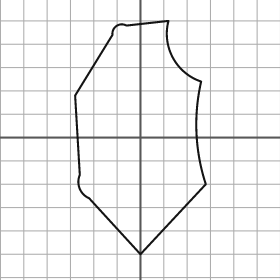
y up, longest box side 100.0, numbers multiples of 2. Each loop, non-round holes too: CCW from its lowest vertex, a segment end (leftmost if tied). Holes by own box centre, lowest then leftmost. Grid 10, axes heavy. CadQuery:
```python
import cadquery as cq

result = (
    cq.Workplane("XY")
    .moveTo(0.0, -50.0)
    .lineTo(28.0, -20.0)
    .threePointArc((24.0, 2.0), (26.0, 24.0))
    .threePointArc((14.0, 34.0), (12.0, 50.0))
    .lineTo(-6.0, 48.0)
    .threePointArc((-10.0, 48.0), (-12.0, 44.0))
    .lineTo(-28.0, 18.0)
    .lineTo(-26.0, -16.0)
    .threePointArc((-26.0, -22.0), (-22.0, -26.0))
    .close()
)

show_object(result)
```